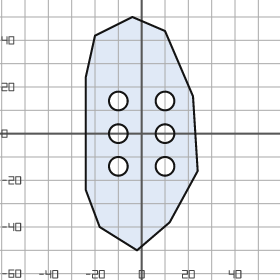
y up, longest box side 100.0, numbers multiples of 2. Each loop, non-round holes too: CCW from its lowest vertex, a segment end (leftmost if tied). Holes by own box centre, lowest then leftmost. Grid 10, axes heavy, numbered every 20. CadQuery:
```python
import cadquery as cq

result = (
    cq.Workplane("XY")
    .moveTo(-2.0, -50.0)
    .lineTo(12.0, -38.0)
    .lineTo(24.0, -16.0)
    .lineTo(22.0, 16.0)
    .lineTo(10.0, 44.0)
    .lineTo(-4.0, 50.0)
    .lineTo(-20.0, 42.0)
    .lineTo(-24.0, 24.0)
    .lineTo(-24.0, -24.0)
    .lineTo(-18.0, -40.0)
    .close()
    .moveTo(-10.0, -14.0)
    .circle(4.0)
    .moveTo(10.0, -14.0)
    .circle(4.0)
    .moveTo(-10.0, 0.0)
    .circle(4.0)
    .moveTo(10.0, 0.0)
    .circle(4.0)
    .moveTo(-10.0, 14.0)
    .circle(4.0)
    .moveTo(10.0, 14.0)
    .circle(4.0)
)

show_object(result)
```